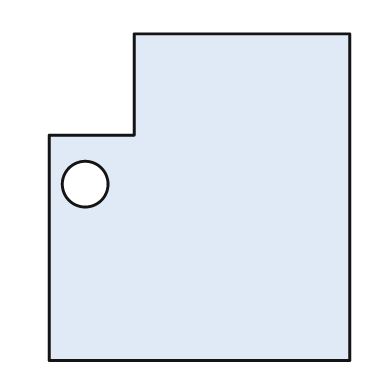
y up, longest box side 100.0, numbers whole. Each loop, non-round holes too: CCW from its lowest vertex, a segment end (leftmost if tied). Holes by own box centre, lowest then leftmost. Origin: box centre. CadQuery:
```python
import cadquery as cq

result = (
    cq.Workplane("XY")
    .moveTo(-46.0, -50.0)
    .lineTo(46.0, -50.0)
    .lineTo(46.0, 50.0)
    .lineTo(-20.0, 50.0)
    .lineTo(-20.0, 19.0)
    .lineTo(-46.0, 19.0)
    .close()
    .moveTo(-35.0, 4.0)
    .circle(7.0)
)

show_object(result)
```